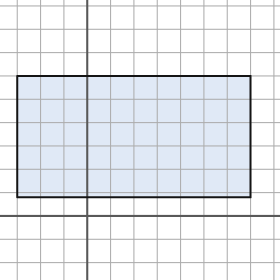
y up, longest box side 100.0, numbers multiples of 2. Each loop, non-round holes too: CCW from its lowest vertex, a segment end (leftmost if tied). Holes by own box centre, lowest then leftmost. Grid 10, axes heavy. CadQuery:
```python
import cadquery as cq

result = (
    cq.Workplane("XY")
    .moveTo(-30.0, 8.0)
    .lineTo(70.0, 8.0)
    .lineTo(70.0, 60.0)
    .lineTo(-30.0, 60.0)
    .close()
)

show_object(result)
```